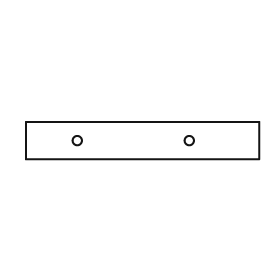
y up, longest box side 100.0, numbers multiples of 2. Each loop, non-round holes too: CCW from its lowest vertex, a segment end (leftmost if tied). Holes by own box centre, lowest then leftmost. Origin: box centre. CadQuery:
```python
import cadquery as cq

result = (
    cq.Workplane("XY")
    .moveTo(-50.0, -8.0)
    .lineTo(50.0, -8.0)
    .lineTo(50.0, 8.0)
    .lineTo(-50.0, 8.0)
    .close()
    .moveTo(-28.0, 0.0)
    .circle(2.0)
    .moveTo(20.0, 0.0)
    .circle(2.0)
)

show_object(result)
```